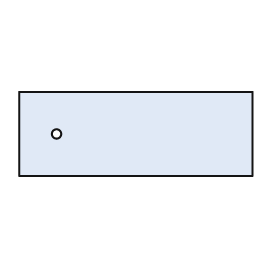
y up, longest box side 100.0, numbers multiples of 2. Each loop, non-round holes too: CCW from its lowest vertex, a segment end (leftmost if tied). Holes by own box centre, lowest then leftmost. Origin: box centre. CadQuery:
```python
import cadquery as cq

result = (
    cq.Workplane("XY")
    .moveTo(-50.0, -18.0)
    .lineTo(50.0, -18.0)
    .lineTo(50.0, 18.0)
    .lineTo(-50.0, 18.0)
    .close()
    .moveTo(-34.0, 0.0)
    .circle(2.0)
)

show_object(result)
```